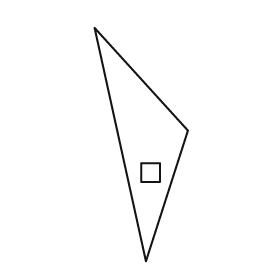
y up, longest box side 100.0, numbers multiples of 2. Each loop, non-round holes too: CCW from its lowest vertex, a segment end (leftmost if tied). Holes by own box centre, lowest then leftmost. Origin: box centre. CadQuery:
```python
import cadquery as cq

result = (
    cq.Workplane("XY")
    .moveTo(2.0, -50.0)
    .lineTo(20.0, 6.0)
    .lineTo(-20.0, 50.0)
    .close()
    .moveTo(0.0, -16.0)
    .lineTo(8.0, -16.0)
    .lineTo(8.0, -8.0)
    .lineTo(0.0, -8.0)
    .close()
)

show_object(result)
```